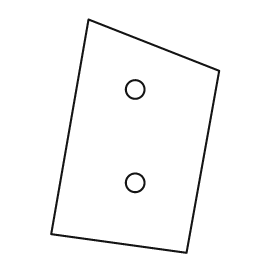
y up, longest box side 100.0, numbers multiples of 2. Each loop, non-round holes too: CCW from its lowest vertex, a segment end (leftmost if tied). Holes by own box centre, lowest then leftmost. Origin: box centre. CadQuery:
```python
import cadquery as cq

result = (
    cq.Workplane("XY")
    .moveTo(22.0, -50.0)
    .lineTo(36.0, 28.0)
    .lineTo(-20.0, 50.0)
    .lineTo(-36.0, -42.0)
    .close()
    .moveTo(0.0, -20.0)
    .circle(4.0)
    .moveTo(0.0, 20.0)
    .circle(4.0)
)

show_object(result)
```